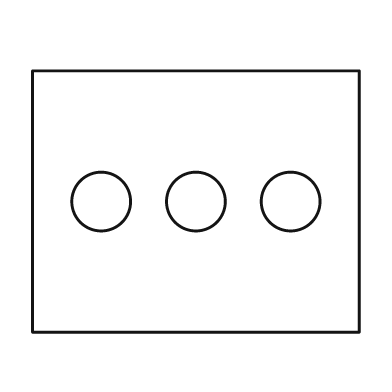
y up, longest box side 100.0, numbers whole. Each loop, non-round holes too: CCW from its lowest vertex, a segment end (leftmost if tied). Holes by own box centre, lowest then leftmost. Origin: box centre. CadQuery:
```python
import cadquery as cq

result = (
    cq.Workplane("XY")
    .moveTo(-50.0, -40.0)
    .lineTo(50.0, -40.0)
    .lineTo(50.0, 40.0)
    .lineTo(-50.0, 40.0)
    .close()
    .moveTo(-29.0, 0.0)
    .circle(9.0)
    .moveTo(0.0, 0.0)
    .circle(9.0)
    .moveTo(29.0, 0.0)
    .circle(9.0)
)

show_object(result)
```